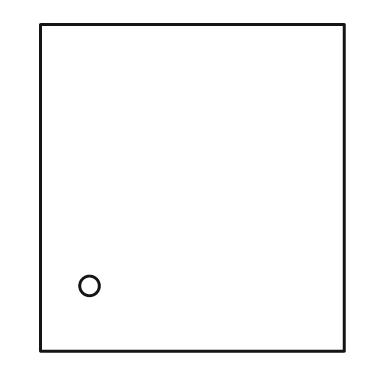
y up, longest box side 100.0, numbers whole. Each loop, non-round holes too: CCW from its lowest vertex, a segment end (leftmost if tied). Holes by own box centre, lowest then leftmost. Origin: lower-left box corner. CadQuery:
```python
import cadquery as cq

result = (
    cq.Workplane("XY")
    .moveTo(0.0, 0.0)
    .lineTo(93.0, 0.0)
    .lineTo(93.0, 100.0)
    .lineTo(0.0, 100.0)
    .close()
    .moveTo(15.0, 20.0)
    .circle(3.0)
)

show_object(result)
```